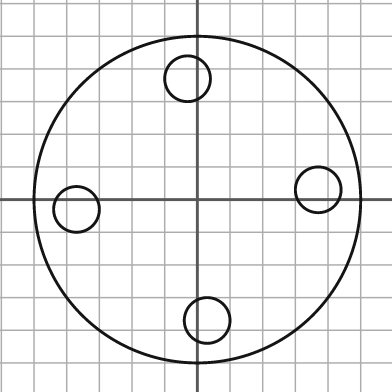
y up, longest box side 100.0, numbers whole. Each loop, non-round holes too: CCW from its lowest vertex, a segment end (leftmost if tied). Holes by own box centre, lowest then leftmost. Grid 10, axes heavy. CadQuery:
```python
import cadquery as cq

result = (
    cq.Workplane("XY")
    .moveTo(0.0, 0.0)
    .circle(50.0)
    .moveTo(3.0, -37.0)
    .circle(7.0)
    .moveTo(-37.0, -3.0)
    .circle(7.0)
    .moveTo(37.0, 3.0)
    .circle(7.0)
    .moveTo(-3.0, 37.0)
    .circle(7.0)
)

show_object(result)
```